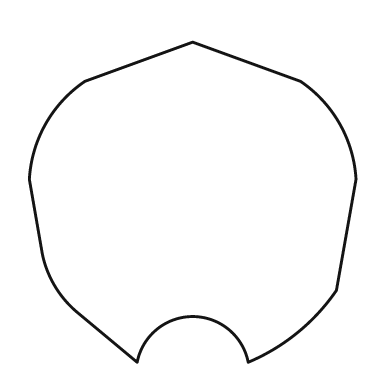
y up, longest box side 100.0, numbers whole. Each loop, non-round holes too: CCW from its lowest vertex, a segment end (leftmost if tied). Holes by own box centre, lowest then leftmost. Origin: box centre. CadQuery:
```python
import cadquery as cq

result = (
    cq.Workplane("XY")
    .moveTo(-17.0, -49.0)
    .threePointArc((0.0, -35.0), (17.0, -49.0))
    .threePointArc((32.0, -40.0), (44.0, -27.0))
    .lineTo(50.0, 7.0)
    .threePointArc((45.0, 24.0), (33.0, 37.0))
    .lineTo(0.0, 49.0)
    .lineTo(-33.0, 37.0)
    .threePointArc((-45.0, 24.0), (-50.0, 7.0))
    .lineTo(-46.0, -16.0)
    .threePointArc((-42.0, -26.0), (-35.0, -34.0))
    .close()
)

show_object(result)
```